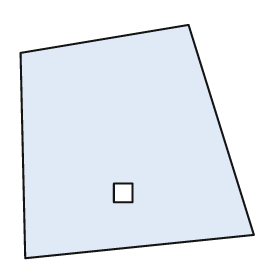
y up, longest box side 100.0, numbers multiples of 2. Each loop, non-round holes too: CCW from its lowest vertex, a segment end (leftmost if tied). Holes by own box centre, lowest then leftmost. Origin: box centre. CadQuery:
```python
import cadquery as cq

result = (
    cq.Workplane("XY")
    .moveTo(-48.0, -50.0)
    .lineTo(50.0, -40.0)
    .lineTo(22.0, 50.0)
    .lineTo(-50.0, 38.0)
    .close()
    .moveTo(-10.0, -26.0)
    .lineTo(-2.0, -26.0)
    .lineTo(-2.0, -18.0)
    .lineTo(-10.0, -18.0)
    .close()
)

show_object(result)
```